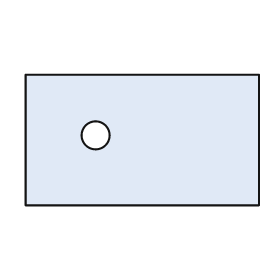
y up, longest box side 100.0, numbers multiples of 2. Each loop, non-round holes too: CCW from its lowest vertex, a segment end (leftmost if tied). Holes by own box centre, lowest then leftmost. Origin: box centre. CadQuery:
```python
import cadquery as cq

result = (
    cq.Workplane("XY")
    .moveTo(-50.0, -28.0)
    .lineTo(50.0, -28.0)
    .lineTo(50.0, 28.0)
    .lineTo(-50.0, 28.0)
    .close()
    .moveTo(-20.0, 2.0)
    .circle(6.0)
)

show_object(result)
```